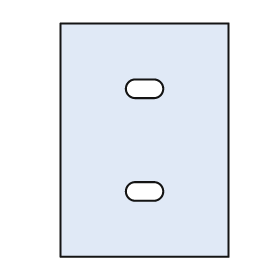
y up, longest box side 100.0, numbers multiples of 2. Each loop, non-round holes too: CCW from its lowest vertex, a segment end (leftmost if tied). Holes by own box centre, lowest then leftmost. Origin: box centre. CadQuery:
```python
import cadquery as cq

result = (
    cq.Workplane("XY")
    .moveTo(-36.0, -50.0)
    .lineTo(36.0, -50.0)
    .lineTo(36.0, 50.0)
    .lineTo(-36.0, 50.0)
    .close()
    .moveTo(-4.0, -26.0)
    .lineTo(4.0, -26.0)
    .threePointArc((8.0, -22.0), (4.0, -18.0))
    .lineTo(-4.0, -18.0)
    .threePointArc((-8.0, -22.0), (-4.0, -26.0))
    .close()
    .moveTo(-4.0, 18.0)
    .lineTo(4.0, 18.0)
    .threePointArc((8.0, 22.0), (4.0, 26.0))
    .lineTo(-4.0, 26.0)
    .threePointArc((-8.0, 22.0), (-4.0, 18.0))
    .close()
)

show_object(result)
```